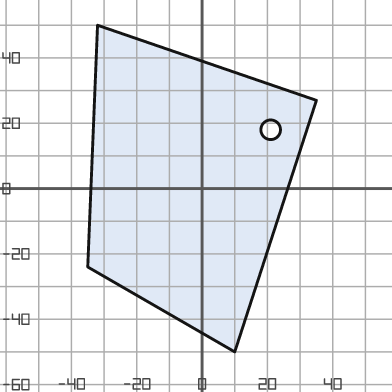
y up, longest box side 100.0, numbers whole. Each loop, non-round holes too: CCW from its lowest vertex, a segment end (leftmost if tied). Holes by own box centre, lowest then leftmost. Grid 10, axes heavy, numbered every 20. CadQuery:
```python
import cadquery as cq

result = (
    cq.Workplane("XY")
    .moveTo(10.0, -50.0)
    .lineTo(35.0, 27.0)
    .lineTo(-32.0, 50.0)
    .lineTo(-35.0, -24.0)
    .close()
    .moveTo(21.0, 18.0)
    .circle(3.0)
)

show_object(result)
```